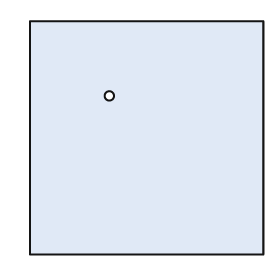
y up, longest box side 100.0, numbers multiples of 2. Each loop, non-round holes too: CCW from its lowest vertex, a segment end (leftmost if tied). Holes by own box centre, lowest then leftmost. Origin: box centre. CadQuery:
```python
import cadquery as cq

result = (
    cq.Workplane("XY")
    .moveTo(-50.0, -50.0)
    .lineTo(50.0, -50.0)
    .lineTo(50.0, 50.0)
    .lineTo(-50.0, 50.0)
    .close()
    .moveTo(-16.0, 18.0)
    .circle(2.0)
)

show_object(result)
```